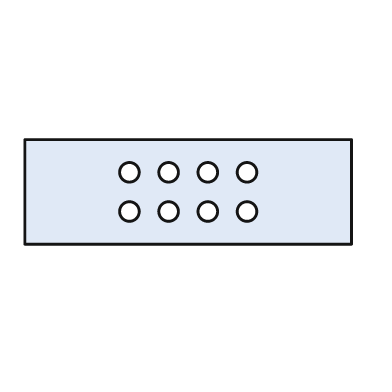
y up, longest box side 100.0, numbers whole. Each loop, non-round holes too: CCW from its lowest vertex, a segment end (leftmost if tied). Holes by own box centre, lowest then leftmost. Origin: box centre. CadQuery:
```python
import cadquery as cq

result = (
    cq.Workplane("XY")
    .moveTo(-50.0, -16.0)
    .lineTo(50.0, -16.0)
    .lineTo(50.0, 16.0)
    .lineTo(-50.0, 16.0)
    .close()
    .moveTo(-18.0, -6.0)
    .circle(3.0)
    .moveTo(-6.0, -6.0)
    .circle(3.0)
    .moveTo(6.0, -6.0)
    .circle(3.0)
    .moveTo(18.0, -6.0)
    .circle(3.0)
    .moveTo(-18.0, 6.0)
    .circle(3.0)
    .moveTo(-6.0, 6.0)
    .circle(3.0)
    .moveTo(6.0, 6.0)
    .circle(3.0)
    .moveTo(18.0, 6.0)
    .circle(3.0)
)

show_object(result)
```